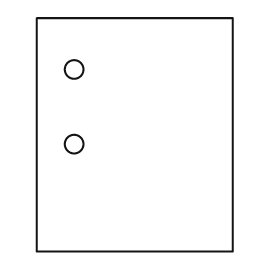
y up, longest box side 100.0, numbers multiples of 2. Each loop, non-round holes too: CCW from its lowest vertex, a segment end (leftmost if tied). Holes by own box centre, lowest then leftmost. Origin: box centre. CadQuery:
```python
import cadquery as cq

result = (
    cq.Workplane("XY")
    .moveTo(-42.0, -50.0)
    .lineTo(42.0, -50.0)
    .lineTo(42.0, 50.0)
    .lineTo(-42.0, 50.0)
    .close()
    .moveTo(-26.0, -4.0)
    .circle(4.0)
    .moveTo(-26.0, 28.0)
    .circle(4.0)
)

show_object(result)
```